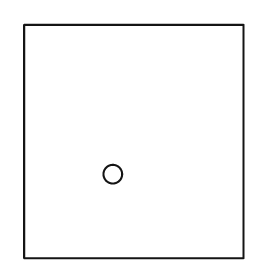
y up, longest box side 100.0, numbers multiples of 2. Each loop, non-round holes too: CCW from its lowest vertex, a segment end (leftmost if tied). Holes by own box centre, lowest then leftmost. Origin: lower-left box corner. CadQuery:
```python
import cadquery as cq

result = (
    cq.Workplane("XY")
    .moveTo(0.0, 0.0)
    .lineTo(94.0, 0.0)
    .lineTo(94.0, 100.0)
    .lineTo(0.0, 100.0)
    .close()
    .moveTo(38.0, 36.0)
    .circle(4.0)
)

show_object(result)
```